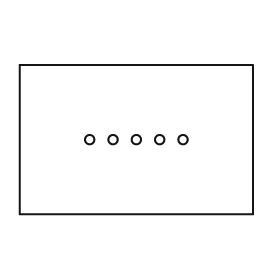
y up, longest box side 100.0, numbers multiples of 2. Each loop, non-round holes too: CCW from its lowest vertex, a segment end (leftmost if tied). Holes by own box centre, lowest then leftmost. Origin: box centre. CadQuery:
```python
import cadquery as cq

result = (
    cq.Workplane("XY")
    .moveTo(-50.0, -32.0)
    .lineTo(50.0, -32.0)
    .lineTo(50.0, 32.0)
    .lineTo(-50.0, 32.0)
    .close()
    .moveTo(-20.0, 0.0)
    .circle(2.0)
    .moveTo(-10.0, 0.0)
    .circle(2.0)
    .moveTo(0.0, 0.0)
    .circle(2.0)
    .moveTo(10.0, 0.0)
    .circle(2.0)
    .moveTo(20.0, 0.0)
    .circle(2.0)
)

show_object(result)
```